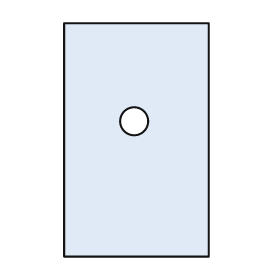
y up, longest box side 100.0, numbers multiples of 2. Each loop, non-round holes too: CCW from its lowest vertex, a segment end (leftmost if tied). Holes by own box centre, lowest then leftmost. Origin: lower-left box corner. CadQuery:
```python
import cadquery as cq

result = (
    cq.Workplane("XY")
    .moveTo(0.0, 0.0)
    .lineTo(62.0, 0.0)
    .lineTo(62.0, 100.0)
    .lineTo(0.0, 100.0)
    .close()
    .moveTo(30.0, 58.0)
    .circle(6.0)
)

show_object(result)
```